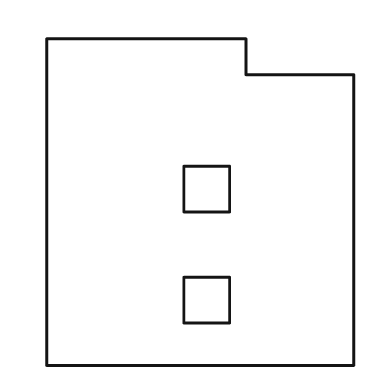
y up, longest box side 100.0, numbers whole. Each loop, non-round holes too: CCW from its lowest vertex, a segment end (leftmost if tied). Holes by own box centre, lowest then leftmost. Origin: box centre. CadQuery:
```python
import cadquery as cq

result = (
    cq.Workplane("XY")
    .moveTo(-47.0, -50.0)
    .lineTo(47.0, -50.0)
    .lineTo(47.0, 39.0)
    .lineTo(14.0, 39.0)
    .lineTo(14.0, 50.0)
    .lineTo(-47.0, 50.0)
    .close()
    .moveTo(-5.0, -37.0)
    .lineTo(9.0, -37.0)
    .lineTo(9.0, -23.0)
    .lineTo(-5.0, -23.0)
    .close()
    .moveTo(-5.0, -3.0)
    .lineTo(9.0, -3.0)
    .lineTo(9.0, 11.0)
    .lineTo(-5.0, 11.0)
    .close()
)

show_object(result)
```